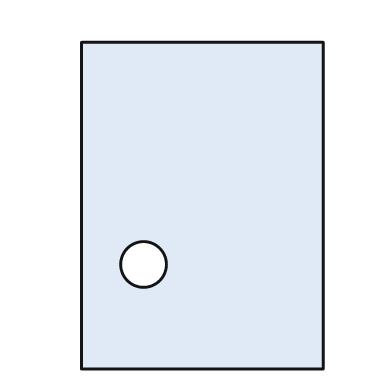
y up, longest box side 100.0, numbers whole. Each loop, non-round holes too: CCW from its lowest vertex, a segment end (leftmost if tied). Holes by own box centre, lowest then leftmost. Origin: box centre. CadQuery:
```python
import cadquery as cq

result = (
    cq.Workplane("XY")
    .moveTo(-37.0, -50.0)
    .lineTo(37.0, -50.0)
    .lineTo(37.0, 50.0)
    .lineTo(-37.0, 50.0)
    .close()
    .moveTo(-18.0, -18.0)
    .circle(7.0)
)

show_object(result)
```